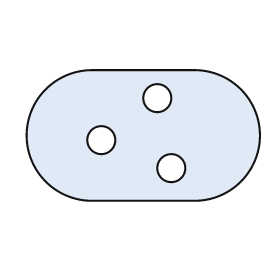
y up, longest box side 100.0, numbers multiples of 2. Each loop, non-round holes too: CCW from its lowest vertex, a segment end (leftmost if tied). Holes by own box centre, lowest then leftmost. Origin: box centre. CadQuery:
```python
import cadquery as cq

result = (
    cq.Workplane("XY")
    .moveTo(-22.0, -28.0)
    .lineTo(22.0, -28.0)
    .threePointArc((50.0, 0.0), (22.0, 28.0))
    .lineTo(-22.0, 28.0)
    .threePointArc((-50.0, 0.0), (-22.0, -28.0))
    .close()
    .moveTo(12.0, -14.0)
    .circle(6.0)
    .moveTo(-18.0, -2.0)
    .circle(6.0)
    .moveTo(6.0, 16.0)
    .circle(6.0)
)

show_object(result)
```